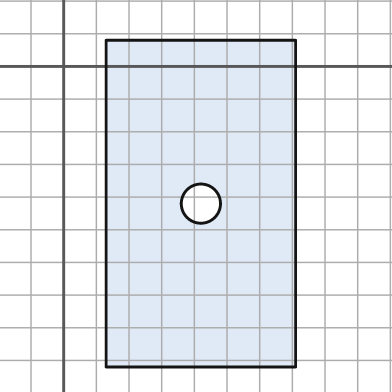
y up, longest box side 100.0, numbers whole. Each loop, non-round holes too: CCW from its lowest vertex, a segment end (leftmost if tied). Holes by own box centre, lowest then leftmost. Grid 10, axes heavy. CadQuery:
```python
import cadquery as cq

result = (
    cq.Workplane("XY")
    .moveTo(13.0, -92.0)
    .lineTo(71.0, -92.0)
    .lineTo(71.0, 8.0)
    .lineTo(13.0, 8.0)
    .close()
    .moveTo(42.0, -42.0)
    .circle(6.0)
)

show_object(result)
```